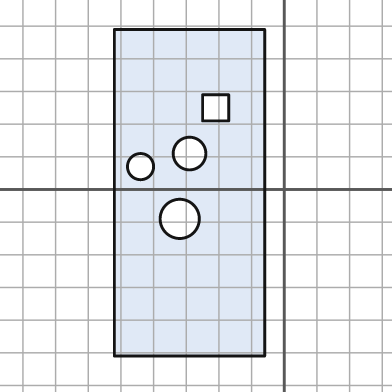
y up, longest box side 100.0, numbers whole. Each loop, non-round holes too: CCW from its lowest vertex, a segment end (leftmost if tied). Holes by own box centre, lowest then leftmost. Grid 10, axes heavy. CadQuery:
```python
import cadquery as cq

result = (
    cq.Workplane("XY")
    .moveTo(-52.0, -51.0)
    .lineTo(-6.0, -51.0)
    .lineTo(-6.0, 49.0)
    .lineTo(-52.0, 49.0)
    .close()
    .moveTo(-32.0, -9.0)
    .circle(6.0)
    .moveTo(-44.0, 7.0)
    .circle(4.0)
    .moveTo(-29.0, 11.0)
    .circle(5.0)
    .moveTo(-25.0, 21.0)
    .lineTo(-17.0, 21.0)
    .lineTo(-17.0, 29.0)
    .lineTo(-25.0, 29.0)
    .close()
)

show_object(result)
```